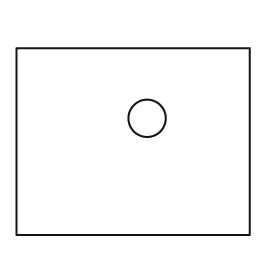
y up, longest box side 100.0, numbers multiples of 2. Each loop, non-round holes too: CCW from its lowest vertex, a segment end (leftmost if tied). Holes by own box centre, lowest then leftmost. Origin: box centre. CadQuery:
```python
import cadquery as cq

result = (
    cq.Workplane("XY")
    .moveTo(-50.0, -40.0)
    .lineTo(50.0, -40.0)
    .lineTo(50.0, 40.0)
    .lineTo(-50.0, 40.0)
    .close()
    .moveTo(6.0, 10.0)
    .circle(8.0)
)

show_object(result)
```